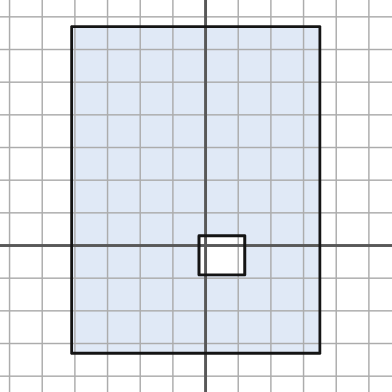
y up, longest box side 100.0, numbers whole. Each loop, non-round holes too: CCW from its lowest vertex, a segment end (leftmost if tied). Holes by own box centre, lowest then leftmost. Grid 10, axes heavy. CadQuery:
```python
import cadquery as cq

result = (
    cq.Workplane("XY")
    .moveTo(-41.0, -33.0)
    .lineTo(35.0, -33.0)
    .lineTo(35.0, 67.0)
    .lineTo(-41.0, 67.0)
    .close()
    .moveTo(-2.0, -9.0)
    .lineTo(12.0, -9.0)
    .lineTo(12.0, 3.0)
    .lineTo(-2.0, 3.0)
    .close()
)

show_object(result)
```